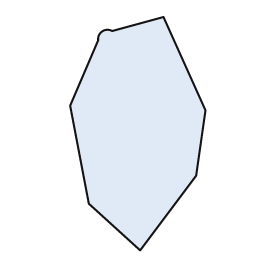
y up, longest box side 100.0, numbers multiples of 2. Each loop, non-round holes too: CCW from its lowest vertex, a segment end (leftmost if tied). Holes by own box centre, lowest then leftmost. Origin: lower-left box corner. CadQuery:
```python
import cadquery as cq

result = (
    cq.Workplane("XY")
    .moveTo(30.0, 0.0)
    .lineTo(54.0, 32.0)
    .lineTo(58.0, 60.0)
    .lineTo(40.0, 100.0)
    .lineTo(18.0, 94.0)
    .threePointArc((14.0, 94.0), (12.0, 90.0))
    .lineTo(0.0, 62.0)
    .lineTo(8.0, 20.0)
    .close()
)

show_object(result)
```